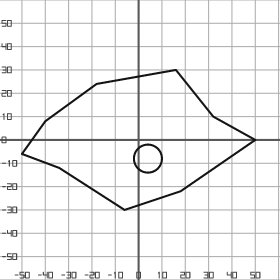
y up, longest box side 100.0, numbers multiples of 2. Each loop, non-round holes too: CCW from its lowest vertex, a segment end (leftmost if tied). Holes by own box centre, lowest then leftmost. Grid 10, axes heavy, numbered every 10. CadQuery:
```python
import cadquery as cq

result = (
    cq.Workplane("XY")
    .moveTo(-6.0, -30.0)
    .lineTo(18.0, -22.0)
    .lineTo(50.0, 0.0)
    .lineTo(32.0, 10.0)
    .lineTo(16.0, 30.0)
    .lineTo(-18.0, 24.0)
    .lineTo(-40.0, 8.0)
    .lineTo(-50.0, -6.0)
    .lineTo(-34.0, -12.0)
    .close()
    .moveTo(4.0, -8.0)
    .circle(6.0)
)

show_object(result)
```